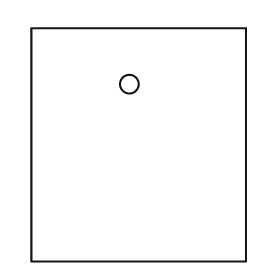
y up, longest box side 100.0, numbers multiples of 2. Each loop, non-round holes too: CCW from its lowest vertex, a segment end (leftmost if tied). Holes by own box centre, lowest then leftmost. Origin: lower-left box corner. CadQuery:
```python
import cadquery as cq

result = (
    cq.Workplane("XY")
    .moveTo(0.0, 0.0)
    .lineTo(92.0, 0.0)
    .lineTo(92.0, 100.0)
    .lineTo(0.0, 100.0)
    .close()
    .moveTo(42.0, 76.0)
    .circle(4.0)
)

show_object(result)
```